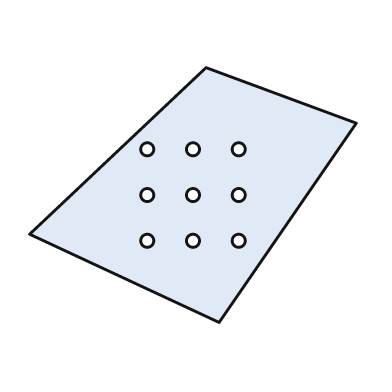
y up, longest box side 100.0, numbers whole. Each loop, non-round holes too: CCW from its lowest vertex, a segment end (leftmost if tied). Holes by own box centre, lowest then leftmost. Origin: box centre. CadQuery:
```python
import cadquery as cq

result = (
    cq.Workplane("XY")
    .moveTo(8.0, -39.0)
    .lineTo(50.0, 22.0)
    .lineTo(4.0, 39.0)
    .lineTo(-50.0, -12.0)
    .close()
    .moveTo(-14.0, -14.0)
    .circle(2.0)
    .moveTo(0.0, -14.0)
    .circle(2.0)
    .moveTo(14.0, -14.0)
    .circle(2.0)
    .moveTo(-14.0, 0.0)
    .circle(2.0)
    .moveTo(0.0, 0.0)
    .circle(2.0)
    .moveTo(14.0, 0.0)
    .circle(2.0)
    .moveTo(-14.0, 14.0)
    .circle(2.0)
    .moveTo(0.0, 14.0)
    .circle(2.0)
    .moveTo(14.0, 14.0)
    .circle(2.0)
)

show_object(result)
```